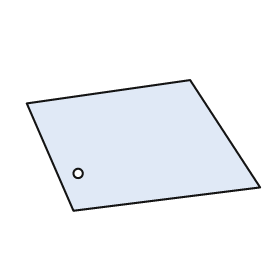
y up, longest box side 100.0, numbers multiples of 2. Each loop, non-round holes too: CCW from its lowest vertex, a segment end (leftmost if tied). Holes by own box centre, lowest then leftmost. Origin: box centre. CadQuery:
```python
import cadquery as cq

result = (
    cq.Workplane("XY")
    .moveTo(-30.0, -28.0)
    .lineTo(50.0, -18.0)
    .lineTo(20.0, 28.0)
    .lineTo(-50.0, 18.0)
    .close()
    .moveTo(-28.0, -12.0)
    .circle(2.0)
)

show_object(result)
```